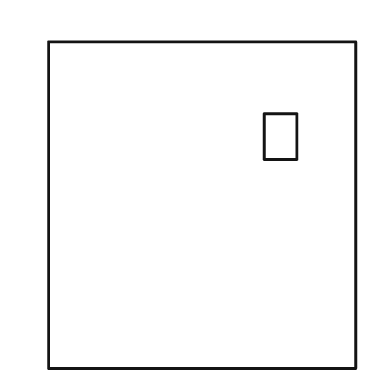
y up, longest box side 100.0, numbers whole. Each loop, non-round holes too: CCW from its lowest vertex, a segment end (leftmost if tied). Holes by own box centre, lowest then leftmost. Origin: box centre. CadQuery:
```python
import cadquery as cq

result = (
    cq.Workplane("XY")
    .moveTo(-47.0, -50.0)
    .lineTo(47.0, -50.0)
    .lineTo(47.0, 50.0)
    .lineTo(-47.0, 50.0)
    .close()
    .moveTo(19.0, 14.0)
    .lineTo(29.0, 14.0)
    .lineTo(29.0, 28.0)
    .lineTo(19.0, 28.0)
    .close()
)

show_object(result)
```